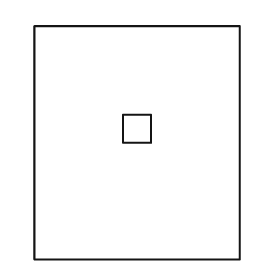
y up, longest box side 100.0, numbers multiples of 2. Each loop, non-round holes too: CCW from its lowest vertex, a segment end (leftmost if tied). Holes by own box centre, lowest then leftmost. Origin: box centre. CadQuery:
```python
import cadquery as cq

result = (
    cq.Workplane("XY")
    .moveTo(-44.0, -50.0)
    .lineTo(44.0, -50.0)
    .lineTo(44.0, 50.0)
    .lineTo(-44.0, 50.0)
    .close()
    .moveTo(-6.0, 0.0)
    .lineTo(6.0, 0.0)
    .lineTo(6.0, 12.0)
    .lineTo(-6.0, 12.0)
    .close()
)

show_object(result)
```